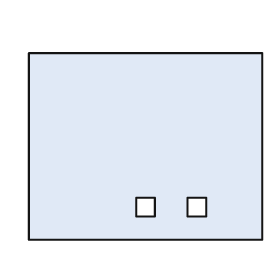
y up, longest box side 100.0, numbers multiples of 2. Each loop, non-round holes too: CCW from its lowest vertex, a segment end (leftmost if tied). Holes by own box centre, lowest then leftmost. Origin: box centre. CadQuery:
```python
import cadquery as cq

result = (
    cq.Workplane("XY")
    .moveTo(-50.0, -40.0)
    .lineTo(50.0, -40.0)
    .lineTo(50.0, 40.0)
    .lineTo(-50.0, 40.0)
    .close()
    .moveTo(-4.0, -30.0)
    .lineTo(4.0, -30.0)
    .lineTo(4.0, -22.0)
    .lineTo(-4.0, -22.0)
    .close()
    .moveTo(18.0, -30.0)
    .lineTo(26.0, -30.0)
    .lineTo(26.0, -22.0)
    .lineTo(18.0, -22.0)
    .close()
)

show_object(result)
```